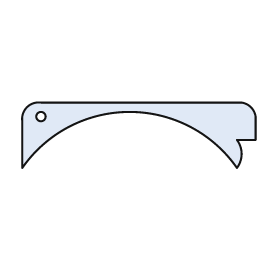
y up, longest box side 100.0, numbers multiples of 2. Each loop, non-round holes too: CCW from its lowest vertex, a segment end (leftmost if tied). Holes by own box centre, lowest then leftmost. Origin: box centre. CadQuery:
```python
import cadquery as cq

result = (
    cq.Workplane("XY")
    .moveTo(-50.0, -14.0)
    .threePointArc((-4.0, 10.0), (42.0, -14.0))
    .threePointArc((44.0, -8.0), (42.0, -2.0))
    .lineTo(50.0, -2.0)
    .lineTo(50.0, 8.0)
    .threePointArc((48.0, 12.0), (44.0, 14.0))
    .lineTo(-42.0, 14.0)
    .threePointArc((-48.0, 12.0), (-50.0, 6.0))
    .close()
    .moveTo(-42.0, 8.0)
    .circle(2.0)
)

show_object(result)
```